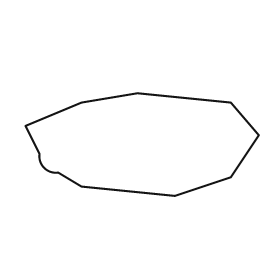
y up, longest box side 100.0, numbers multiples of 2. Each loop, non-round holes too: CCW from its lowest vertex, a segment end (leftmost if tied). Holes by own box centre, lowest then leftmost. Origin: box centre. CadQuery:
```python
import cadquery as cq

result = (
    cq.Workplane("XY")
    .moveTo(14.0, -22.0)
    .lineTo(38.0, -14.0)
    .lineTo(50.0, 4.0)
    .lineTo(38.0, 18.0)
    .lineTo(-2.0, 22.0)
    .lineTo(-26.0, 18.0)
    .lineTo(-50.0, 8.0)
    .lineTo(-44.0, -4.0)
    .threePointArc((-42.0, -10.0), (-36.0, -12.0))
    .lineTo(-26.0, -18.0)
    .close()
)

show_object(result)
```